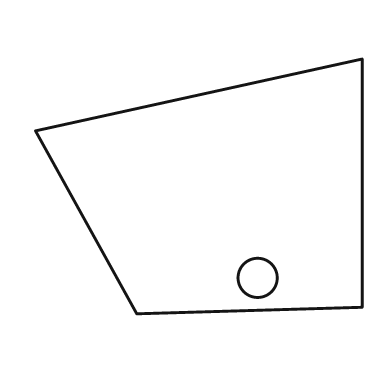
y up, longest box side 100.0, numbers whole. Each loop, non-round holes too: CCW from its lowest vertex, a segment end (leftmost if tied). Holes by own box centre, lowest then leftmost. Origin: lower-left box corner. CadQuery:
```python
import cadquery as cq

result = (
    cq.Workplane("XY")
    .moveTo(31.0, 0.0)
    .lineTo(100.0, 2.0)
    .lineTo(100.0, 78.0)
    .lineTo(0.0, 56.0)
    .close()
    .moveTo(68.0, 11.0)
    .circle(6.0)
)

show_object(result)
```